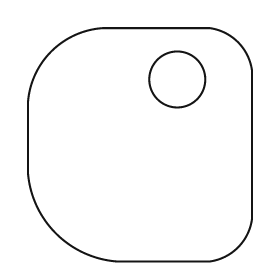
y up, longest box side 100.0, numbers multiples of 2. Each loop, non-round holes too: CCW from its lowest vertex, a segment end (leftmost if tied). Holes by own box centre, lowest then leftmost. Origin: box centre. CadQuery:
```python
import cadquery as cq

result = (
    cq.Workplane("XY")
    .moveTo(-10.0, -50.0)
    .lineTo(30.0, -50.0)
    .threePointArc((42.0, -44.0), (48.0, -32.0))
    .lineTo(48.0, 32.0)
    .threePointArc((42.0, 44.0), (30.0, 50.0))
    .lineTo(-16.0, 50.0)
    .threePointArc((-38.0, 40.0), (-48.0, 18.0))
    .lineTo(-48.0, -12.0)
    .threePointArc((-36.0, -38.0), (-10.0, -50.0))
    .close()
    .moveTo(16.0, 28.0)
    .circle(12.0)
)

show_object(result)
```